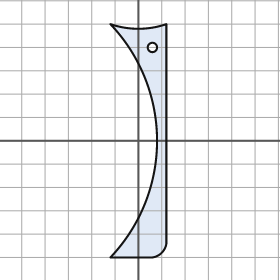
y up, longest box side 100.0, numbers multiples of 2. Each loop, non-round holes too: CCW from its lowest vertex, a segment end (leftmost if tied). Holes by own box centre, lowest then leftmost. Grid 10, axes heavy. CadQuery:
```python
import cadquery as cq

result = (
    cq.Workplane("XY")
    .moveTo(-12.0, -50.0)
    .lineTo(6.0, -50.0)
    .threePointArc((10.0, -48.0), (12.0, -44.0))
    .lineTo(12.0, 50.0)
    .threePointArc((0.0, 48.0), (-12.0, 50.0))
    .threePointArc((8.0, 0.0), (-12.0, -50.0))
    .close()
    .moveTo(6.0, 40.0)
    .circle(2.0)
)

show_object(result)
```